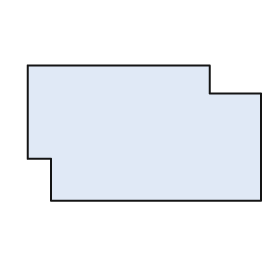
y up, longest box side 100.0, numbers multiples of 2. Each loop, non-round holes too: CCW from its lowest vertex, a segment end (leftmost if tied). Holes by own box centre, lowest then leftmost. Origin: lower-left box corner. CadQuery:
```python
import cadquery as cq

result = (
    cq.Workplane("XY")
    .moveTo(10.0, 0.0)
    .lineTo(100.0, 0.0)
    .lineTo(100.0, 46.0)
    .lineTo(78.0, 46.0)
    .lineTo(78.0, 58.0)
    .lineTo(0.0, 58.0)
    .lineTo(0.0, 18.0)
    .lineTo(10.0, 18.0)
    .close()
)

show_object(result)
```